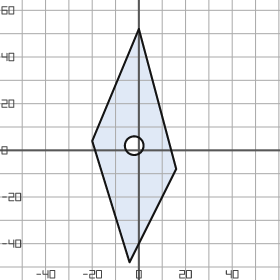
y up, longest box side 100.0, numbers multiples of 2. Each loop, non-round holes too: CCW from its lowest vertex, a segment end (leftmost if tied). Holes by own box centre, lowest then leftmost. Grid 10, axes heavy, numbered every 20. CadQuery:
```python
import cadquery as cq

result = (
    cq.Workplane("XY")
    .moveTo(-4.0, -48.0)
    .lineTo(16.0, -8.0)
    .lineTo(0.0, 52.0)
    .lineTo(-20.0, 4.0)
    .close()
    .moveTo(-2.0, 2.0)
    .circle(4.0)
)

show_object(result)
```